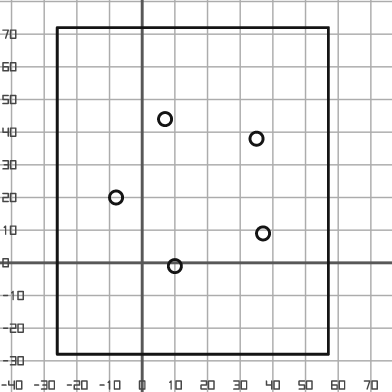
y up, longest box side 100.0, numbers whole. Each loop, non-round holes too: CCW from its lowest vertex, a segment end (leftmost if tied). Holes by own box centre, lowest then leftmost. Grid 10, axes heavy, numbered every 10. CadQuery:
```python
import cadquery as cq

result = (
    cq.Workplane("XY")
    .moveTo(-26.0, -28.0)
    .lineTo(57.0, -28.0)
    .lineTo(57.0, 72.0)
    .lineTo(-26.0, 72.0)
    .close()
    .moveTo(10.0, -1.0)
    .circle(2.0)
    .moveTo(37.0, 9.0)
    .circle(2.0)
    .moveTo(-8.0, 20.0)
    .circle(2.0)
    .moveTo(35.0, 38.0)
    .circle(2.0)
    .moveTo(7.0, 44.0)
    .circle(2.0)
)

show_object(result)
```